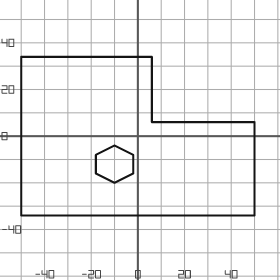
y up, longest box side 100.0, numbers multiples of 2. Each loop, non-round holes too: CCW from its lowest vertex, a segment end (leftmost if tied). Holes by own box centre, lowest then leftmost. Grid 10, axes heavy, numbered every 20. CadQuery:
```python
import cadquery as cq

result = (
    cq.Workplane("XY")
    .moveTo(-50.0, -34.0)
    .lineTo(50.0, -34.0)
    .lineTo(50.0, 6.0)
    .lineTo(6.0, 6.0)
    .lineTo(6.0, 34.0)
    .lineTo(-50.0, 34.0)
    .close()
    .moveTo(-10.0, -20.0)
    .lineTo(-2.0, -16.0)
    .lineTo(-2.0, -8.0)
    .lineTo(-10.0, -4.0)
    .lineTo(-18.0, -8.0)
    .lineTo(-18.0, -16.0)
    .close()
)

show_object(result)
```